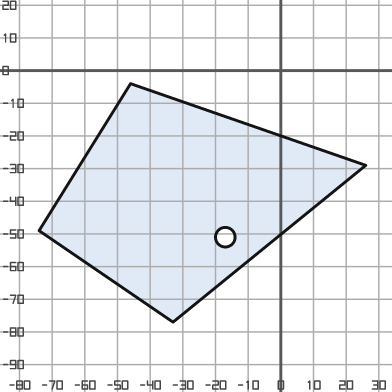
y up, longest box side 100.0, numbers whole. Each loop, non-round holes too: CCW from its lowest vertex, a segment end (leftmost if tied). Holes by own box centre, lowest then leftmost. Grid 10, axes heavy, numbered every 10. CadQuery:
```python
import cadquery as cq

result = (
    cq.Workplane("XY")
    .moveTo(-33.0, -77.0)
    .lineTo(26.0, -29.0)
    .lineTo(-46.0, -4.0)
    .lineTo(-74.0, -49.0)
    .close()
    .moveTo(-17.0, -51.0)
    .circle(3.0)
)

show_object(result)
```